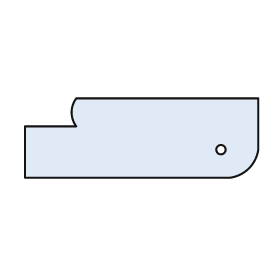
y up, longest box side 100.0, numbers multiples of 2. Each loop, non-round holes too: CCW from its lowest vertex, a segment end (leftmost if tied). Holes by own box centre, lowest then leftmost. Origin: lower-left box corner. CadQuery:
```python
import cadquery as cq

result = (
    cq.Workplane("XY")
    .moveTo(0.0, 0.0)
    .lineTo(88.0, 0.0)
    .threePointArc((96.0, 4.0), (100.0, 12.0))
    .lineTo(100.0, 34.0)
    .lineTo(22.0, 34.0)
    .threePointArc((20.0, 28.0), (22.0, 22.0))
    .lineTo(0.0, 22.0)
    .close()
    .moveTo(84.0, 12.0)
    .circle(2.0)
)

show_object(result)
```